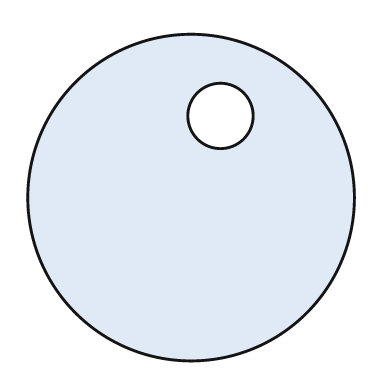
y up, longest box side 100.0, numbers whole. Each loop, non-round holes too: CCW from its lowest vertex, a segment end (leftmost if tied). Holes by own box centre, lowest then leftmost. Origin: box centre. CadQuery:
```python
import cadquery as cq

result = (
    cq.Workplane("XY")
    .moveTo(0.0, 0.0)
    .circle(50.0)
    .moveTo(9.0, 25.0)
    .circle(10.0)
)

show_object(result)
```